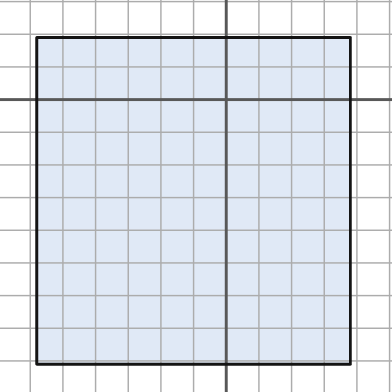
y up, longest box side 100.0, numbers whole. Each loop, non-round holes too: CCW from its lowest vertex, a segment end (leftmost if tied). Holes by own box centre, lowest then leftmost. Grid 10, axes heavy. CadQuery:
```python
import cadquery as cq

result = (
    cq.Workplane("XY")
    .moveTo(-58.0, -81.0)
    .lineTo(38.0, -81.0)
    .lineTo(38.0, 19.0)
    .lineTo(-58.0, 19.0)
    .close()
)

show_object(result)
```